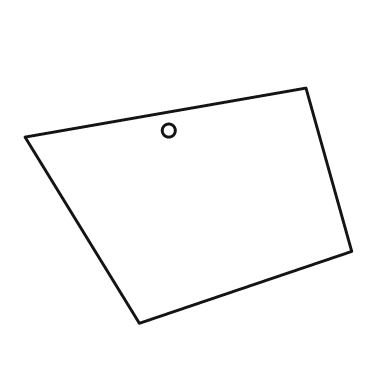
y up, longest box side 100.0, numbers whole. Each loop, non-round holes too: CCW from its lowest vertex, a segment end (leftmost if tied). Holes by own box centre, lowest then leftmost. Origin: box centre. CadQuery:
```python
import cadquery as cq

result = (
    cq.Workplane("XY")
    .moveTo(-15.0, -36.0)
    .lineTo(50.0, -14.0)
    .lineTo(36.0, 36.0)
    .lineTo(-50.0, 21.0)
    .close()
    .moveTo(-6.0, 23.0)
    .circle(2.0)
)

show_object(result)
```